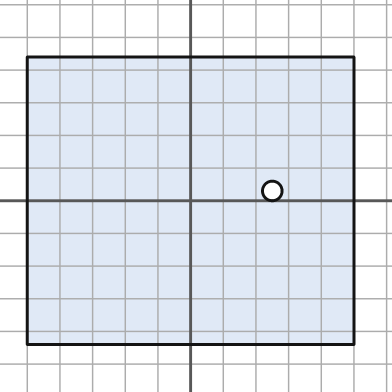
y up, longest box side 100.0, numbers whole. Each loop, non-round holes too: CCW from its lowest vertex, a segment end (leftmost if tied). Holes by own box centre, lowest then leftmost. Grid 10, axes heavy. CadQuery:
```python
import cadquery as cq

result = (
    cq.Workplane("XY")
    .moveTo(-50.0, -44.0)
    .lineTo(50.0, -44.0)
    .lineTo(50.0, 44.0)
    .lineTo(-50.0, 44.0)
    .close()
    .moveTo(25.0, 3.0)
    .circle(3.0)
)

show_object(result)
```